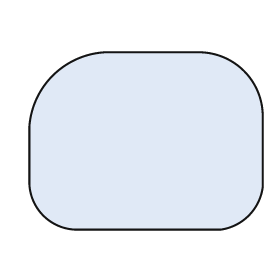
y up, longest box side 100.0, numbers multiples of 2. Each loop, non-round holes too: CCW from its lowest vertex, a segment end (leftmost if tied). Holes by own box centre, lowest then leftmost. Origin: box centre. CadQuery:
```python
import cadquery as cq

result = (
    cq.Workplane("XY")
    .moveTo(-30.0, -38.0)
    .lineTo(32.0, -38.0)
    .threePointArc((44.0, -32.0), (50.0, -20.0))
    .lineTo(50.0, 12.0)
    .threePointArc((42.0, 30.0), (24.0, 38.0))
    .lineTo(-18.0, 38.0)
    .threePointArc((-40.0, 28.0), (-50.0, 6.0))
    .lineTo(-50.0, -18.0)
    .threePointArc((-44.0, -32.0), (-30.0, -38.0))
    .close()
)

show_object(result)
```